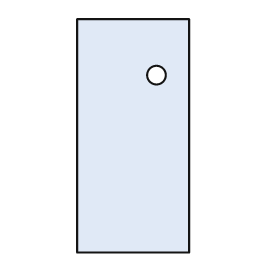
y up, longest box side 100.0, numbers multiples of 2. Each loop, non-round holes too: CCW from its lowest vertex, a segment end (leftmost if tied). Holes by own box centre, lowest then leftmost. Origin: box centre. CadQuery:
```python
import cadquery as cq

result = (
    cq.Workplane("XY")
    .moveTo(-24.0, -50.0)
    .lineTo(24.0, -50.0)
    .lineTo(24.0, 50.0)
    .lineTo(-24.0, 50.0)
    .close()
    .moveTo(10.0, 26.0)
    .circle(4.0)
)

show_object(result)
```